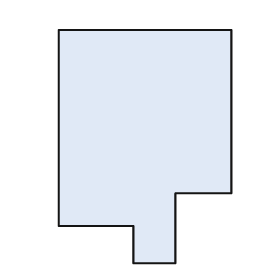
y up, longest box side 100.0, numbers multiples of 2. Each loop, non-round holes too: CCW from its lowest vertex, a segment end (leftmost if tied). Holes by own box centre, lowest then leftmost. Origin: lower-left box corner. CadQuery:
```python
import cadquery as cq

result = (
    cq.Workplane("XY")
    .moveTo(32.0, 0.0)
    .lineTo(50.0, 0.0)
    .lineTo(50.0, 30.0)
    .lineTo(74.0, 30.0)
    .lineTo(74.0, 100.0)
    .lineTo(0.0, 100.0)
    .lineTo(0.0, 16.0)
    .lineTo(32.0, 16.0)
    .close()
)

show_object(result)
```